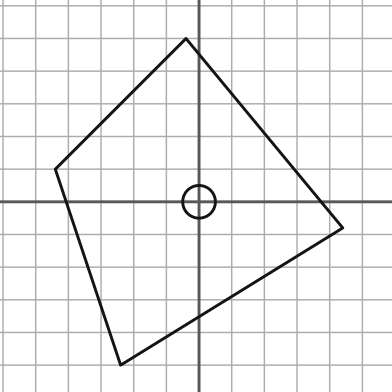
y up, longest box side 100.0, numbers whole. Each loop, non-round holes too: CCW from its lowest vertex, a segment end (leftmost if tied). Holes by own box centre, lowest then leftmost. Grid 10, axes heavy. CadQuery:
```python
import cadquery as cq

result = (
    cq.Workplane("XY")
    .moveTo(-24.0, -50.0)
    .lineTo(44.0, -8.0)
    .lineTo(-4.0, 50.0)
    .lineTo(-44.0, 10.0)
    .close()
    .moveTo(0.0, 0.0)
    .circle(5.0)
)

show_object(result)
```